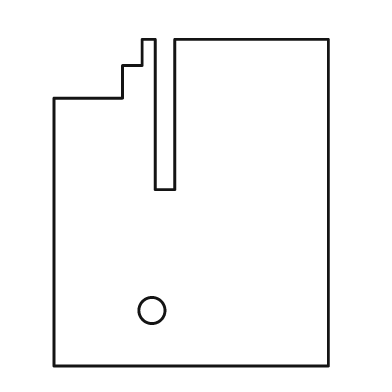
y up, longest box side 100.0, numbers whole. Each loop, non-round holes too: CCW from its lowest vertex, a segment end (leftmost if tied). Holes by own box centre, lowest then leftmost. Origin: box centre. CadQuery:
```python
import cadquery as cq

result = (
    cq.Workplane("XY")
    .moveTo(-42.0, -50.0)
    .lineTo(42.0, -50.0)
    .lineTo(42.0, 50.0)
    .lineTo(-5.0, 50.0)
    .lineTo(-5.0, 4.0)
    .lineTo(-11.0, 4.0)
    .lineTo(-11.0, 50.0)
    .lineTo(-15.0, 50.0)
    .lineTo(-15.0, 42.0)
    .lineTo(-21.0, 42.0)
    .lineTo(-21.0, 32.0)
    .lineTo(-42.0, 32.0)
    .close()
    .moveTo(-12.0, -33.0)
    .circle(4.0)
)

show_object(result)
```